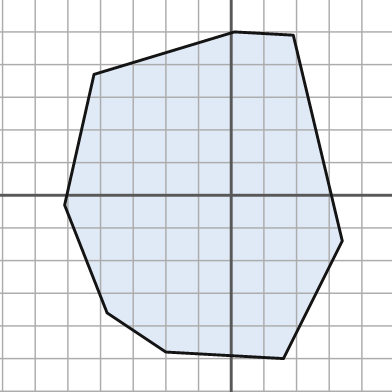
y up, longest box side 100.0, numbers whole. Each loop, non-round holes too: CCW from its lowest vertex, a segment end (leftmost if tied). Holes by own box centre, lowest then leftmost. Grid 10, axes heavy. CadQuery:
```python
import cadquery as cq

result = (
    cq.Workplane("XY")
    .moveTo(16.0, -50.0)
    .lineTo(34.0, -14.0)
    .lineTo(19.0, 49.0)
    .lineTo(1.0, 50.0)
    .lineTo(-42.0, 37.0)
    .lineTo(-51.0, -3.0)
    .lineTo(-38.0, -36.0)
    .lineTo(-20.0, -48.0)
    .close()
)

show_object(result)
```